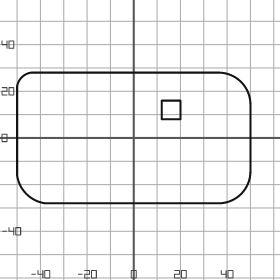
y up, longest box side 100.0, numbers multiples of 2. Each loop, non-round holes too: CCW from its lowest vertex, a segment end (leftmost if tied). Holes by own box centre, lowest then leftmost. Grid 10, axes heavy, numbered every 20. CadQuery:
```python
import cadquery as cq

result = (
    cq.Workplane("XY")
    .moveTo(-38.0, -28.0)
    .lineTo(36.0, -28.0)
    .threePointArc((46.0, -24.0), (50.0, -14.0))
    .lineTo(50.0, 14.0)
    .threePointArc((46.0, 24.0), (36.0, 28.0))
    .lineTo(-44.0, 28.0)
    .threePointArc((-48.0, 26.0), (-50.0, 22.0))
    .lineTo(-50.0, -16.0)
    .threePointArc((-46.0, -24.0), (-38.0, -28.0))
    .close()
    .moveTo(12.0, 8.0)
    .lineTo(20.0, 8.0)
    .lineTo(20.0, 16.0)
    .lineTo(12.0, 16.0)
    .close()
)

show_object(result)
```